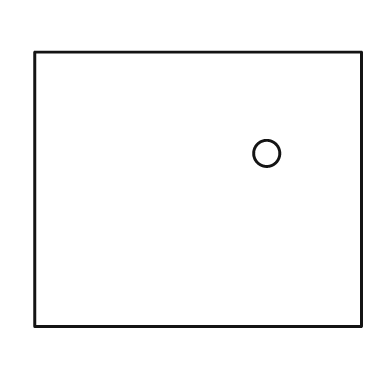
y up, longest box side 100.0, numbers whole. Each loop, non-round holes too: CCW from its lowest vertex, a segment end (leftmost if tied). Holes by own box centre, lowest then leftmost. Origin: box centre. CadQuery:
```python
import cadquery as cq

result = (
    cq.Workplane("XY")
    .moveTo(-50.0, -42.0)
    .lineTo(50.0, -42.0)
    .lineTo(50.0, 42.0)
    .lineTo(-50.0, 42.0)
    .close()
    .moveTo(21.0, 11.0)
    .circle(4.0)
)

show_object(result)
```